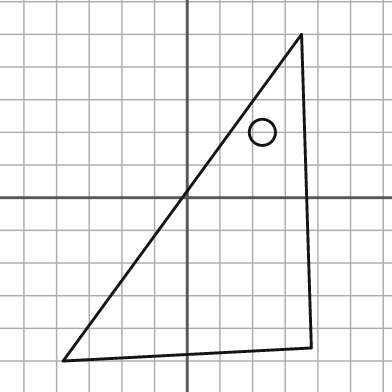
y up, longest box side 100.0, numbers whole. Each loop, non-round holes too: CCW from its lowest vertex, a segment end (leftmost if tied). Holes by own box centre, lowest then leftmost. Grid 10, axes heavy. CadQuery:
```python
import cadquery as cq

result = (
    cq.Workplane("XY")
    .moveTo(-38.0, -50.0)
    .lineTo(38.0, -46.0)
    .lineTo(35.0, 50.0)
    .close()
    .moveTo(23.0, 20.0)
    .circle(4.0)
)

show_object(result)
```